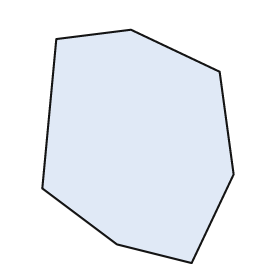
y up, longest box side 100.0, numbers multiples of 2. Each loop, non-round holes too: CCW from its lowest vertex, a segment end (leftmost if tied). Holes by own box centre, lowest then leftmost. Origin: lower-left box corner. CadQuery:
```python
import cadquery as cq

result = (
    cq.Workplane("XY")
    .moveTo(64.0, 0.0)
    .lineTo(82.0, 38.0)
    .lineTo(76.0, 82.0)
    .lineTo(38.0, 100.0)
    .lineTo(6.0, 96.0)
    .lineTo(0.0, 32.0)
    .lineTo(32.0, 8.0)
    .close()
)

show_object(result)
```